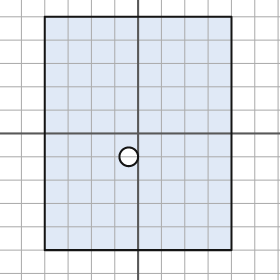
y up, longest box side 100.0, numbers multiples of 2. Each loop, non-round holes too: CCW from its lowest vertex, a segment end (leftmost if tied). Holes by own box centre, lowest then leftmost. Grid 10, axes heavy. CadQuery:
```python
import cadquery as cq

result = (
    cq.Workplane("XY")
    .moveTo(-40.0, -50.0)
    .lineTo(40.0, -50.0)
    .lineTo(40.0, 50.0)
    .lineTo(-40.0, 50.0)
    .close()
    .moveTo(-4.0, -10.0)
    .circle(4.0)
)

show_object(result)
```